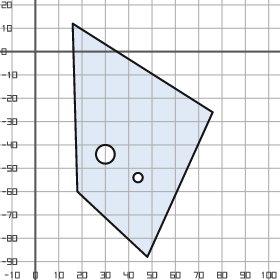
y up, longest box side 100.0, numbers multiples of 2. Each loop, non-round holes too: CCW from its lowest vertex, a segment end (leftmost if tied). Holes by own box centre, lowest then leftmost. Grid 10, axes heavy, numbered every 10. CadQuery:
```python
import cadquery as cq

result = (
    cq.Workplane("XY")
    .moveTo(48.0, -88.0)
    .lineTo(76.0, -26.0)
    .lineTo(16.0, 12.0)
    .lineTo(18.0, -60.0)
    .close()
    .moveTo(44.0, -54.0)
    .circle(2.0)
    .moveTo(30.0, -44.0)
    .circle(4.0)
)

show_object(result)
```